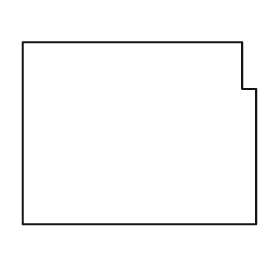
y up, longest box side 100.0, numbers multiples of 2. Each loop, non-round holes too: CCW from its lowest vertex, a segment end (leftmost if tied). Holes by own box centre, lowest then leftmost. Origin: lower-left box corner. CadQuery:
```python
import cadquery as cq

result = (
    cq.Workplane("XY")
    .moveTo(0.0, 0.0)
    .lineTo(100.0, 0.0)
    .lineTo(100.0, 58.0)
    .lineTo(94.0, 58.0)
    .lineTo(94.0, 78.0)
    .lineTo(0.0, 78.0)
    .close()
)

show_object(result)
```